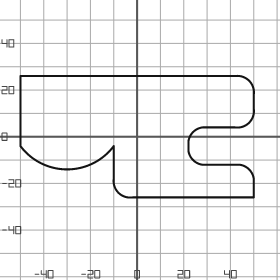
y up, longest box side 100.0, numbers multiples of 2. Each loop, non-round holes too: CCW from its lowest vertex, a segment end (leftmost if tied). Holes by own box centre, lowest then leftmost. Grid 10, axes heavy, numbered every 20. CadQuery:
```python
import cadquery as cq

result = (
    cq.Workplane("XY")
    .moveTo(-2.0, -26.0)
    .lineTo(50.0, -26.0)
    .lineTo(50.0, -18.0)
    .threePointArc((48.0, -14.0), (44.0, -12.0))
    .lineTo(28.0, -12.0)
    .threePointArc((24.0, -10.0), (22.0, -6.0))
    .lineTo(22.0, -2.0)
    .threePointArc((24.0, 2.0), (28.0, 4.0))
    .lineTo(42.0, 4.0)
    .threePointArc((48.0, 6.0), (50.0, 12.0))
    .lineTo(50.0, 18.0)
    .threePointArc((48.0, 24.0), (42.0, 26.0))
    .lineTo(-50.0, 26.0)
    .lineTo(-50.0, -4.0)
    .threePointArc((-30.0, -14.0), (-10.0, -4.0))
    .lineTo(-10.0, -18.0)
    .threePointArc((-8.0, -24.0), (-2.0, -26.0))
    .close()
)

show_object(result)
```